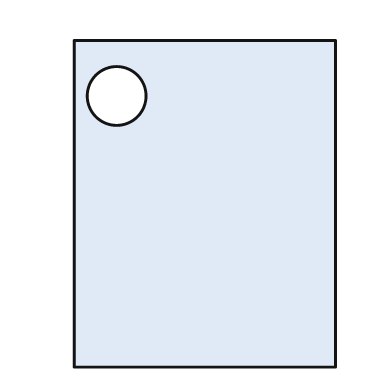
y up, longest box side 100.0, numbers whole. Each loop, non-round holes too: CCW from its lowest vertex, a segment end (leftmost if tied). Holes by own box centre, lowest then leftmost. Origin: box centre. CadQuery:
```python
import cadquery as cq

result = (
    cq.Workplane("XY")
    .moveTo(-40.0, -50.0)
    .lineTo(40.0, -50.0)
    .lineTo(40.0, 50.0)
    .lineTo(-40.0, 50.0)
    .close()
    .moveTo(-27.0, 33.0)
    .circle(9.0)
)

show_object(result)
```